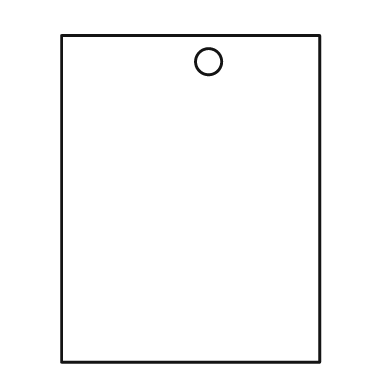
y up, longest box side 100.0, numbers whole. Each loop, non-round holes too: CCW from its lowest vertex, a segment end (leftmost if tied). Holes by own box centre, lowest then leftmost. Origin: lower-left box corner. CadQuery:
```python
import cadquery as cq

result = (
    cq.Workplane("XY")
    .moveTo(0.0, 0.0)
    .lineTo(79.0, 0.0)
    .lineTo(79.0, 100.0)
    .lineTo(0.0, 100.0)
    .close()
    .moveTo(45.0, 92.0)
    .circle(4.0)
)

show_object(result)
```